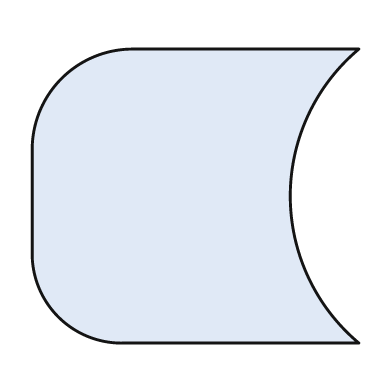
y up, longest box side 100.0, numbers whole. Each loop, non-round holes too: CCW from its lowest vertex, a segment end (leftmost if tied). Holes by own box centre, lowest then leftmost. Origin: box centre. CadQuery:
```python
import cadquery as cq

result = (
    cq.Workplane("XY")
    .moveTo(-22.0, -45.0)
    .lineTo(50.0, -45.0)
    .threePointArc((29.0, 0.0), (50.0, 45.0))
    .lineTo(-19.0, 45.0)
    .threePointArc((-41.0, 36.0), (-50.0, 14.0))
    .lineTo(-50.0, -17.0)
    .threePointArc((-42.0, -37.0), (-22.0, -45.0))
    .close()
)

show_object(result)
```